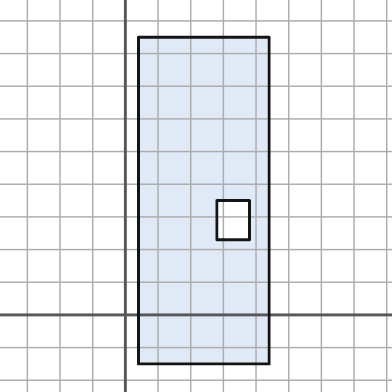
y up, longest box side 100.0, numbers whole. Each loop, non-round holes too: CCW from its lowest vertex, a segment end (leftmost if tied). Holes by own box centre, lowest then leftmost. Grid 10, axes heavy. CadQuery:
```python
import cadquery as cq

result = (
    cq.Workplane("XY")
    .moveTo(4.0, -15.0)
    .lineTo(44.0, -15.0)
    .lineTo(44.0, 85.0)
    .lineTo(4.0, 85.0)
    .close()
    .moveTo(28.0, 23.0)
    .lineTo(38.0, 23.0)
    .lineTo(38.0, 35.0)
    .lineTo(28.0, 35.0)
    .close()
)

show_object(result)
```